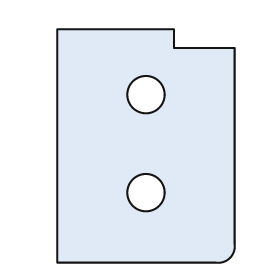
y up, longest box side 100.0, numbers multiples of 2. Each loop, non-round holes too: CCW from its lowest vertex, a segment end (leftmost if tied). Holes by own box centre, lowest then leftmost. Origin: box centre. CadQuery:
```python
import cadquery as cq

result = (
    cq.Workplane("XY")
    .moveTo(-38.0, -50.0)
    .lineTo(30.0, -50.0)
    .threePointArc((36.0, -48.0), (38.0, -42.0))
    .lineTo(38.0, 42.0)
    .lineTo(12.0, 42.0)
    .lineTo(12.0, 50.0)
    .lineTo(-38.0, 50.0)
    .close()
    .moveTo(0.0, -20.0)
    .circle(8.0)
    .moveTo(0.0, 22.0)
    .circle(8.0)
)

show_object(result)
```